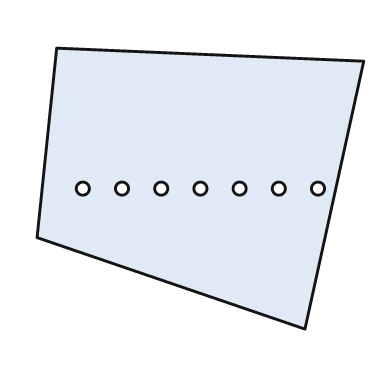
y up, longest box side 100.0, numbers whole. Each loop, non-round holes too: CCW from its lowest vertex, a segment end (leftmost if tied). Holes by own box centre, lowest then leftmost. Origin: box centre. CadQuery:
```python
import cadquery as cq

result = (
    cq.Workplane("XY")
    .moveTo(32.0, -43.0)
    .lineTo(50.0, 39.0)
    .lineTo(-44.0, 43.0)
    .lineTo(-50.0, -15.0)
    .close()
    .moveTo(-36.0, 0.0)
    .circle(2.0)
    .moveTo(-24.0, 0.0)
    .circle(2.0)
    .moveTo(-12.0, 0.0)
    .circle(2.0)
    .moveTo(0.0, 0.0)
    .circle(2.0)
    .moveTo(12.0, 0.0)
    .circle(2.0)
    .moveTo(24.0, 0.0)
    .circle(2.0)
    .moveTo(36.0, 0.0)
    .circle(2.0)
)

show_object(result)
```